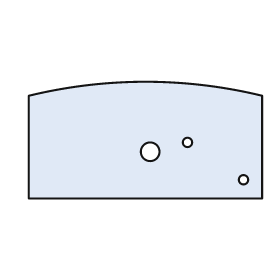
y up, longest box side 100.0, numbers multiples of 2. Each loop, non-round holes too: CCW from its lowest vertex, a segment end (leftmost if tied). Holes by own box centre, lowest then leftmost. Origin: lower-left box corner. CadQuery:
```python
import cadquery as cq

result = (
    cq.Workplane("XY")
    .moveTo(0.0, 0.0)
    .lineTo(100.0, 0.0)
    .lineTo(100.0, 44.0)
    .threePointArc((50.0, 50.0), (0.0, 44.0))
    .close()
    .moveTo(92.0, 8.0)
    .circle(2.0)
    .moveTo(52.0, 20.0)
    .circle(4.0)
    .moveTo(68.0, 24.0)
    .circle(2.0)
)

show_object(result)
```